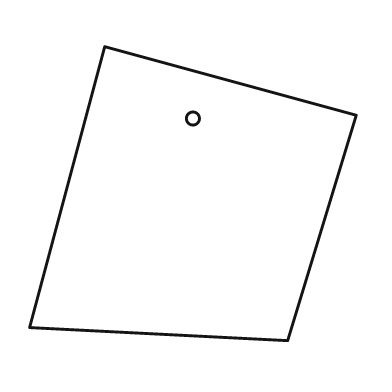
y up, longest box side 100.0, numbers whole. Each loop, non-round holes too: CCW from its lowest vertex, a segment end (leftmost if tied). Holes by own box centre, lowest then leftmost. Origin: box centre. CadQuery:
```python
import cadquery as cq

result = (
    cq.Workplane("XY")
    .moveTo(29.0, -45.0)
    .lineTo(50.0, 24.0)
    .lineTo(-27.0, 45.0)
    .lineTo(-50.0, -41.0)
    .close()
    .moveTo(0.0, 23.0)
    .circle(2.0)
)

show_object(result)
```